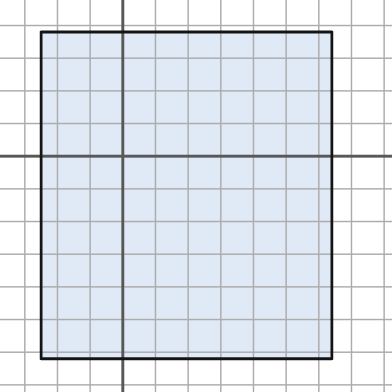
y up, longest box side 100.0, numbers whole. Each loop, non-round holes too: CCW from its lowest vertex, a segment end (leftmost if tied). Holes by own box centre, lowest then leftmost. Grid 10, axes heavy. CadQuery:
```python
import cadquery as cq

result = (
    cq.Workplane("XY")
    .moveTo(-25.0, -62.0)
    .lineTo(64.0, -62.0)
    .lineTo(64.0, 38.0)
    .lineTo(-25.0, 38.0)
    .close()
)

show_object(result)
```